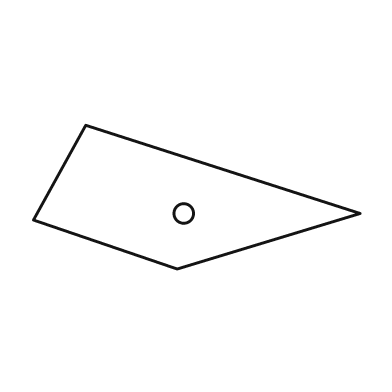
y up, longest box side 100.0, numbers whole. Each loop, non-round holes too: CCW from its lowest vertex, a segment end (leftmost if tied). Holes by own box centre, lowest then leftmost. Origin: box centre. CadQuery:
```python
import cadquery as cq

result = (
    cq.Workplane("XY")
    .moveTo(-6.0, -22.0)
    .lineTo(50.0, -5.0)
    .lineTo(-34.0, 22.0)
    .lineTo(-50.0, -7.0)
    .close()
    .moveTo(-4.0, -5.0)
    .circle(3.0)
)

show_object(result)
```